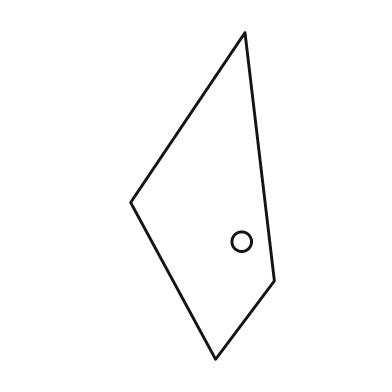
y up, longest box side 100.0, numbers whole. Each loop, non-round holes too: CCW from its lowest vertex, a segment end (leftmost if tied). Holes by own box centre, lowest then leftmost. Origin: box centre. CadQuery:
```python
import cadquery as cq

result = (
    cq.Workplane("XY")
    .moveTo(4.0, -50.0)
    .lineTo(22.0, -26.0)
    .lineTo(13.0, 50.0)
    .lineTo(-22.0, -2.0)
    .close()
    .moveTo(12.0, -14.0)
    .circle(3.0)
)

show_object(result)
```